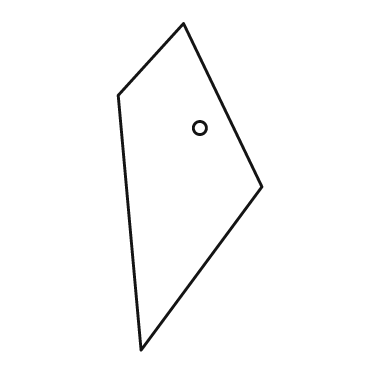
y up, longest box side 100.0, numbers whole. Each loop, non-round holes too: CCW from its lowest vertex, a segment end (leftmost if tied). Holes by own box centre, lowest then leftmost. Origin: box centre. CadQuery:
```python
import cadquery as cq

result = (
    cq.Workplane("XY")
    .moveTo(-15.0, -50.0)
    .lineTo(22.0, 0.0)
    .lineTo(-2.0, 50.0)
    .lineTo(-22.0, 28.0)
    .close()
    .moveTo(3.0, 18.0)
    .circle(2.0)
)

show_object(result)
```